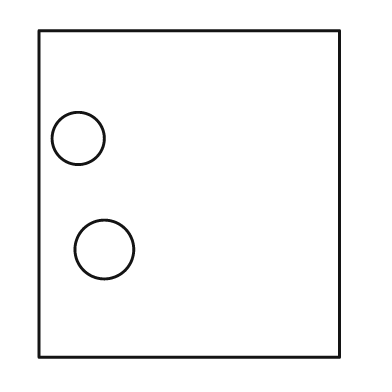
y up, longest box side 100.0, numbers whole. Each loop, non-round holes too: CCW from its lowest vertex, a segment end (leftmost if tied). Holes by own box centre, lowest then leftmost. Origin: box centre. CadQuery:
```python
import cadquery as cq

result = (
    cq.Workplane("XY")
    .moveTo(-46.0, -50.0)
    .lineTo(46.0, -50.0)
    .lineTo(46.0, 50.0)
    .lineTo(-46.0, 50.0)
    .close()
    .moveTo(-26.0, -17.0)
    .circle(9.0)
    .moveTo(-34.0, 17.0)
    .circle(8.0)
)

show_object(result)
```